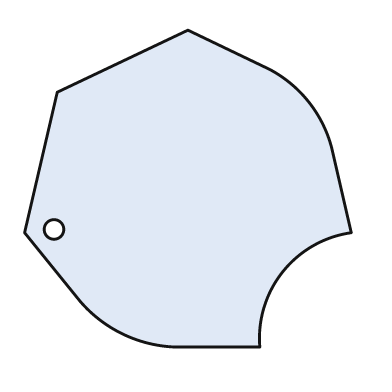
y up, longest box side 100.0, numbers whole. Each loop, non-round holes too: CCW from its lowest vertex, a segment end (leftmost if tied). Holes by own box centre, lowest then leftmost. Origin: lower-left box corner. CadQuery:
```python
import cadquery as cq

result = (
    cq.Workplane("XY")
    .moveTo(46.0, 0.0)
    .lineTo(72.0, 0.0)
    .threePointArc((79.0, 23.0), (100.0, 35.0))
    .lineTo(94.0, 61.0)
    .threePointArc((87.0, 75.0), (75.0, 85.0))
    .lineTo(50.0, 97.0)
    .lineTo(10.0, 78.0)
    .lineTo(0.0, 35.0)
    .lineTo(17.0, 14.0)
    .threePointArc((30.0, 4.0), (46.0, 0.0))
    .close()
    .moveTo(9.0, 36.0)
    .circle(3.0)
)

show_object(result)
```